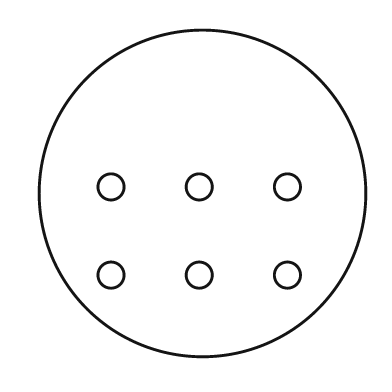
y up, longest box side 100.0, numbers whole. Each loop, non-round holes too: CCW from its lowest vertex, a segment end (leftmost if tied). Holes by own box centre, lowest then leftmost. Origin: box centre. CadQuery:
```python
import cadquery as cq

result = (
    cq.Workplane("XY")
    .moveTo(0.0, 0.0)
    .circle(50.0)
    .moveTo(-28.0, -25.0)
    .circle(4.0)
    .moveTo(-1.0, -25.0)
    .circle(4.0)
    .moveTo(26.0, -25.0)
    .circle(4.0)
    .moveTo(-28.0, 2.0)
    .circle(4.0)
    .moveTo(-1.0, 2.0)
    .circle(4.0)
    .moveTo(26.0, 2.0)
    .circle(4.0)
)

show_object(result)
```